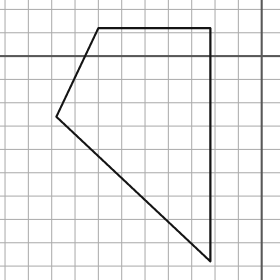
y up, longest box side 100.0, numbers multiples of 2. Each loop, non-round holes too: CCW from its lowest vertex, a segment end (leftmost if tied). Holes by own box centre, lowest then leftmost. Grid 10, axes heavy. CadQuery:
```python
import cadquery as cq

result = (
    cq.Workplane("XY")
    .moveTo(-22.0, -88.0)
    .lineTo(-22.0, 12.0)
    .lineTo(-70.0, 12.0)
    .lineTo(-88.0, -26.0)
    .close()
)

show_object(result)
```